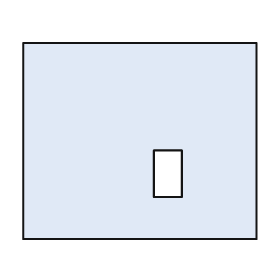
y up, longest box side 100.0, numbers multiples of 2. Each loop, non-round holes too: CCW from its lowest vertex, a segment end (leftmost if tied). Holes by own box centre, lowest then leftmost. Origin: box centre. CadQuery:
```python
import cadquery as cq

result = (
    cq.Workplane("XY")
    .moveTo(-50.0, -42.0)
    .lineTo(50.0, -42.0)
    .lineTo(50.0, 42.0)
    .lineTo(-50.0, 42.0)
    .close()
    .moveTo(6.0, -24.0)
    .lineTo(18.0, -24.0)
    .lineTo(18.0, -4.0)
    .lineTo(6.0, -4.0)
    .close()
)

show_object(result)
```